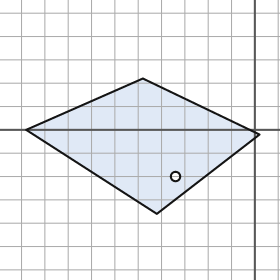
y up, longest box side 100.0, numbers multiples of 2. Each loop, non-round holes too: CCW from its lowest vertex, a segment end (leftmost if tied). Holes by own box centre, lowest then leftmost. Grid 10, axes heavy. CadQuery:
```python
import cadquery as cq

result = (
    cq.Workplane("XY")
    .moveTo(-42.0, -36.0)
    .lineTo(2.0, -2.0)
    .lineTo(-48.0, 22.0)
    .lineTo(-98.0, 0.0)
    .close()
    .moveTo(-34.0, -20.0)
    .circle(2.0)
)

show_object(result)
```